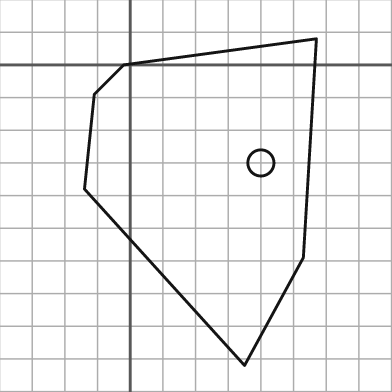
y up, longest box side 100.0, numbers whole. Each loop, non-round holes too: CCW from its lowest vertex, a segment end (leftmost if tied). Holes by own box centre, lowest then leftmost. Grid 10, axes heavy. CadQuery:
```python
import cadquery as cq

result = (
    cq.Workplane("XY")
    .moveTo(35.0, -92.0)
    .lineTo(53.0, -59.0)
    .lineTo(57.0, 8.0)
    .lineTo(-2.0, 0.0)
    .lineTo(-11.0, -9.0)
    .lineTo(-14.0, -38.0)
    .close()
    .moveTo(40.0, -30.0)
    .circle(4.0)
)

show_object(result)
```